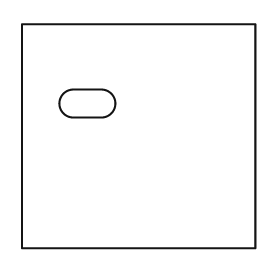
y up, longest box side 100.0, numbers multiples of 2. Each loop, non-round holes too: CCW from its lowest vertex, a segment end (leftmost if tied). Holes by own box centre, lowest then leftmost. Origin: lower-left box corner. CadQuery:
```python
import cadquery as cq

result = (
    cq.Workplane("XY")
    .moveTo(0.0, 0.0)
    .lineTo(100.0, 0.0)
    .lineTo(100.0, 96.0)
    .lineTo(0.0, 96.0)
    .close()
    .moveTo(22.0, 56.0)
    .lineTo(34.0, 56.0)
    .threePointArc((40.0, 62.0), (34.0, 68.0))
    .lineTo(22.0, 68.0)
    .threePointArc((16.0, 62.0), (22.0, 56.0))
    .close()
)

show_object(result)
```